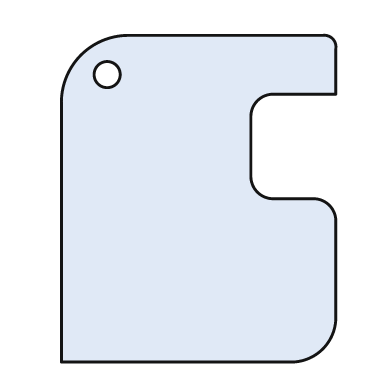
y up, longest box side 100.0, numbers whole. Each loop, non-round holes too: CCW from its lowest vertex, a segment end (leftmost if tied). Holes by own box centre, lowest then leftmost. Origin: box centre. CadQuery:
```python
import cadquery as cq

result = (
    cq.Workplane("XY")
    .moveTo(-42.0, -50.0)
    .lineTo(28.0, -50.0)
    .threePointArc((38.0, -46.0), (42.0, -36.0))
    .lineTo(42.0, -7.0)
    .threePointArc((40.0, -2.0), (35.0, 0.0))
    .lineTo(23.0, 0.0)
    .threePointArc((18.0, 2.0), (16.0, 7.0))
    .lineTo(16.0, 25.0)
    .threePointArc((18.0, 30.0), (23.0, 32.0))
    .lineTo(42.0, 32.0)
    .lineTo(42.0, 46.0)
    .threePointArc((41.0, 49.0), (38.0, 50.0))
    .lineTo(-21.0, 50.0)
    .threePointArc((-36.0, 44.0), (-42.0, 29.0))
    .close()
    .moveTo(-28.0, 38.0)
    .circle(4.0)
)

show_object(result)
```